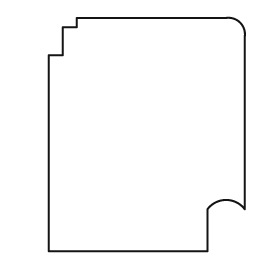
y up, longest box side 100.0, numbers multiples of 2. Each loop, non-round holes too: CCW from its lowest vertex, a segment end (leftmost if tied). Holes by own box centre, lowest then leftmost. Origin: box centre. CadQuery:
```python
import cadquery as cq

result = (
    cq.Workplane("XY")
    .moveTo(-42.0, -50.0)
    .lineTo(26.0, -50.0)
    .lineTo(26.0, -32.0)
    .threePointArc((34.0, -28.0), (42.0, -32.0))
    .lineTo(42.0, 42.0)
    .threePointArc((40.0, 48.0), (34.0, 50.0))
    .lineTo(-30.0, 50.0)
    .lineTo(-30.0, 46.0)
    .lineTo(-36.0, 46.0)
    .lineTo(-36.0, 34.0)
    .lineTo(-42.0, 34.0)
    .close()
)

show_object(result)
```